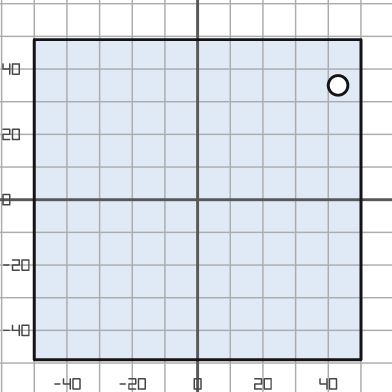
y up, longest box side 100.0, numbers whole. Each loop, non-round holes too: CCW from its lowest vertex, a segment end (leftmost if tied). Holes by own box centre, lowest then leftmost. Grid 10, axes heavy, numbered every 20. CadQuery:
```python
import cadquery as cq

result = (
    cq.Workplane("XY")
    .moveTo(-50.0, -49.0)
    .lineTo(50.0, -49.0)
    .lineTo(50.0, 49.0)
    .lineTo(-50.0, 49.0)
    .close()
    .moveTo(43.0, 35.0)
    .circle(3.0)
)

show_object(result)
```